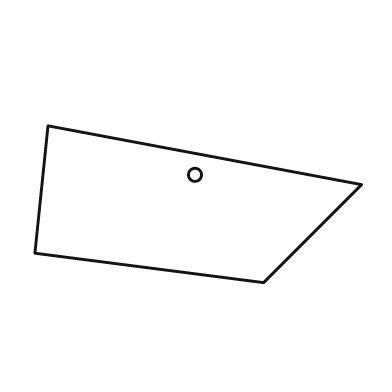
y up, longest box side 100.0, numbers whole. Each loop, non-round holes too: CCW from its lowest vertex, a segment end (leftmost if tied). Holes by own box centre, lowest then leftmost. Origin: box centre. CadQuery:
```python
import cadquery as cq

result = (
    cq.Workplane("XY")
    .moveTo(20.0, -24.0)
    .lineTo(50.0, 6.0)
    .lineTo(-46.0, 24.0)
    .lineTo(-50.0, -15.0)
    .close()
    .moveTo(-1.0, 9.0)
    .circle(2.0)
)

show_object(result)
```